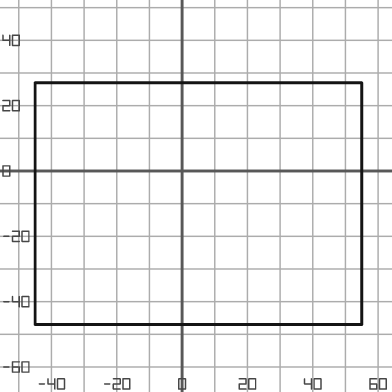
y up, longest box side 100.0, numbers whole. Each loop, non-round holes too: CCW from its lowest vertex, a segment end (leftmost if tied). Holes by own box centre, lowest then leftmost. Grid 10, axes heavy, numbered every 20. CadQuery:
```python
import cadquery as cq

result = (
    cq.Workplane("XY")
    .moveTo(-45.0, -47.0)
    .lineTo(55.0, -47.0)
    .lineTo(55.0, 27.0)
    .lineTo(-45.0, 27.0)
    .close()
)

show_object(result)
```